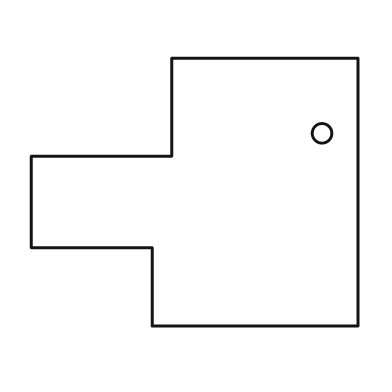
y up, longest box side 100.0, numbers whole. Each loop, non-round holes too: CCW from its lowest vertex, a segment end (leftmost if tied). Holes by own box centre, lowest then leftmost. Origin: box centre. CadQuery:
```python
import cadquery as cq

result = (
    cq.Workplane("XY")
    .moveTo(-13.0, -41.0)
    .lineTo(50.0, -41.0)
    .lineTo(50.0, 41.0)
    .lineTo(-7.0, 41.0)
    .lineTo(-7.0, 11.0)
    .lineTo(-50.0, 11.0)
    .lineTo(-50.0, -17.0)
    .lineTo(-13.0, -17.0)
    .close()
    .moveTo(39.0, 18.0)
    .circle(3.0)
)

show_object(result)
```